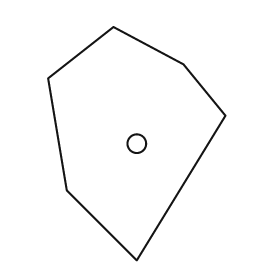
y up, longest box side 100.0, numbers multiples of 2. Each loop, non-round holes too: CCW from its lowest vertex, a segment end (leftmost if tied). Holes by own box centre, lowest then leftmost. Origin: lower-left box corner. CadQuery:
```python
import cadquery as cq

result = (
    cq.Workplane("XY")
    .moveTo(38.0, 0.0)
    .lineTo(76.0, 62.0)
    .lineTo(58.0, 84.0)
    .lineTo(28.0, 100.0)
    .lineTo(0.0, 78.0)
    .lineTo(8.0, 30.0)
    .close()
    .moveTo(38.0, 50.0)
    .circle(4.0)
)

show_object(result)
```